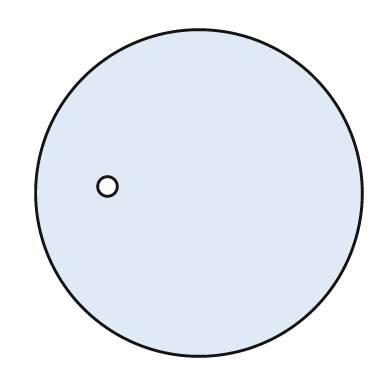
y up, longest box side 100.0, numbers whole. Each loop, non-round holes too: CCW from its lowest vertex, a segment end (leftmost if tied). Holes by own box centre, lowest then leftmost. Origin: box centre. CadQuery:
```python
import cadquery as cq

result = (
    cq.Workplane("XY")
    .moveTo(0.0, 0.0)
    .circle(50.0)
    .moveTo(-28.0, 2.0)
    .circle(3.0)
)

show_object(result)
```